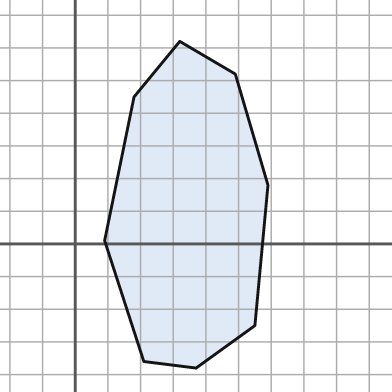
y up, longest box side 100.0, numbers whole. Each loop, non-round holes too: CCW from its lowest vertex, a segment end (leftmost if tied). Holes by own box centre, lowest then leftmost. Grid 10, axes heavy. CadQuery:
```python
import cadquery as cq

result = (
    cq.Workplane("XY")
    .moveTo(37.0, -38.0)
    .lineTo(55.0, -25.0)
    .lineTo(59.0, 18.0)
    .lineTo(49.0, 52.0)
    .lineTo(32.0, 62.0)
    .lineTo(18.0, 45.0)
    .lineTo(9.0, 1.0)
    .lineTo(21.0, -36.0)
    .close()
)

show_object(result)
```